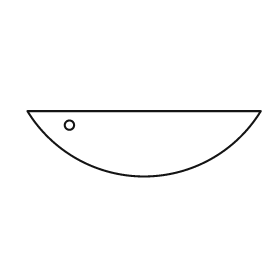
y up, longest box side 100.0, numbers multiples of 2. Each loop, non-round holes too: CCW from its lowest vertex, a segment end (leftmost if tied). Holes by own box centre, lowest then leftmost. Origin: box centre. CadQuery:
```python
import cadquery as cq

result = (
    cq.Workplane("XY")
    .moveTo(-50.0, 14.0)
    .threePointArc((0.0, -14.0), (50.0, 14.0))
    .close()
    .moveTo(-32.0, 8.0)
    .circle(2.0)
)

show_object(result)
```